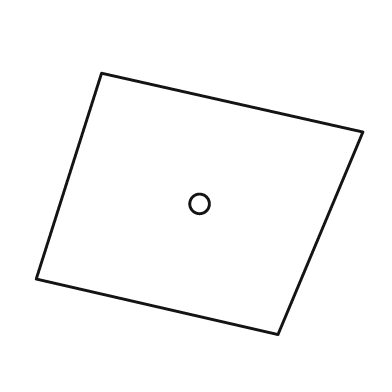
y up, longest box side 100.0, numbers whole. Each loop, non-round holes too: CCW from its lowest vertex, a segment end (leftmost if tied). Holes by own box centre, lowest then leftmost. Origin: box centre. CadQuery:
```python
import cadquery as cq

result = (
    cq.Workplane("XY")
    .moveTo(24.0, -40.0)
    .lineTo(50.0, 22.0)
    .lineTo(-30.0, 40.0)
    .lineTo(-50.0, -23.0)
    .close()
    .moveTo(0.0, 0.0)
    .circle(3.0)
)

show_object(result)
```